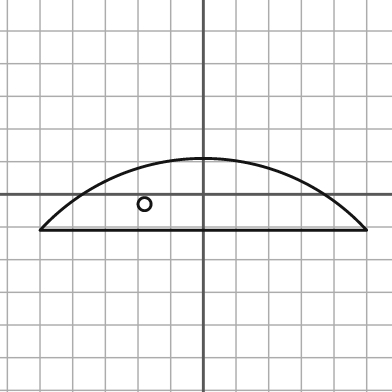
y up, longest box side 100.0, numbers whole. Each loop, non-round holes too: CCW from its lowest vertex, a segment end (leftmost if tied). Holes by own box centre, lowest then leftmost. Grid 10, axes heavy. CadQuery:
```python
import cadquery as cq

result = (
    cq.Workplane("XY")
    .moveTo(-50.0, -11.0)
    .lineTo(50.0, -11.0)
    .threePointArc((0.0, 11.0), (-50.0, -11.0))
    .close()
    .moveTo(-18.0, -3.0)
    .circle(2.0)
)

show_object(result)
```